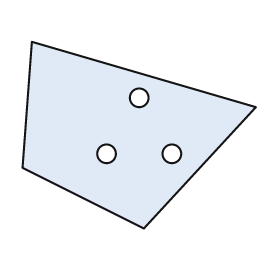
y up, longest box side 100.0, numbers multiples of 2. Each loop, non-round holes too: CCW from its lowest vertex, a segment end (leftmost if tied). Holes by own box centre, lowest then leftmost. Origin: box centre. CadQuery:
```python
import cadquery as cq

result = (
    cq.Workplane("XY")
    .moveTo(2.0, -40.0)
    .lineTo(50.0, 12.0)
    .lineTo(-46.0, 40.0)
    .lineTo(-50.0, -14.0)
    .close()
    .moveTo(-14.0, -8.0)
    .circle(4.0)
    .moveTo(14.0, -8.0)
    .circle(4.0)
    .moveTo(0.0, 16.0)
    .circle(4.0)
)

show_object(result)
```